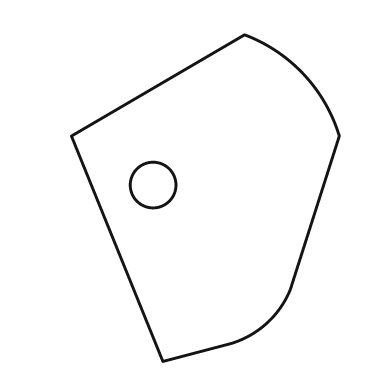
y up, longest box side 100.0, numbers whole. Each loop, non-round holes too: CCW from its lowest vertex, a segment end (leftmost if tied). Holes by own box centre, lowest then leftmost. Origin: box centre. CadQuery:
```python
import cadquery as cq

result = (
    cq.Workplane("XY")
    .moveTo(-13.0, -50.0)
    .lineTo(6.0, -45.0)
    .threePointArc((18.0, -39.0), (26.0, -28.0))
    .lineTo(41.0, 19.0)
    .threePointArc((30.0, 38.0), (12.0, 50.0))
    .lineTo(-41.0, 19.0)
    .close()
    .moveTo(-16.0, 4.0)
    .circle(7.0)
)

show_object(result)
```